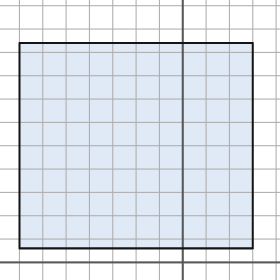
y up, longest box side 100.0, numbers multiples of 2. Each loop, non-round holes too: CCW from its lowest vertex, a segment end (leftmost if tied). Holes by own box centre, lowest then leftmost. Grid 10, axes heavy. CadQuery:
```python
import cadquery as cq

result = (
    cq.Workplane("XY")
    .moveTo(-70.0, 6.0)
    .lineTo(30.0, 6.0)
    .lineTo(30.0, 94.0)
    .lineTo(-70.0, 94.0)
    .close()
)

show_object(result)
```